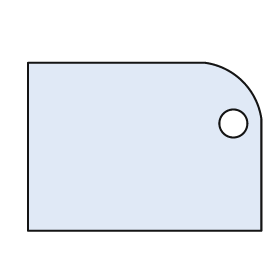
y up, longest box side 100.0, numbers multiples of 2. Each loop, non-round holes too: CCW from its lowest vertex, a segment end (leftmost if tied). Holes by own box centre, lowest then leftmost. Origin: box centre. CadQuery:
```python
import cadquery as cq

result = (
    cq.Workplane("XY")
    .moveTo(-50.0, -36.0)
    .lineTo(50.0, -36.0)
    .lineTo(50.0, 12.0)
    .threePointArc((42.0, 28.0), (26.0, 36.0))
    .lineTo(-50.0, 36.0)
    .close()
    .moveTo(38.0, 10.0)
    .circle(6.0)
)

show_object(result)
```